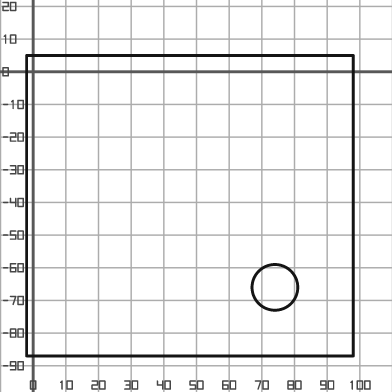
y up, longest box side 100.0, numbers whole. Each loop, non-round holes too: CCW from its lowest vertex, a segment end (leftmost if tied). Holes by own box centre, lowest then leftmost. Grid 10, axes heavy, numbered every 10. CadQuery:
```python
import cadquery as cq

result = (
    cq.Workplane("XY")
    .moveTo(-2.0, -87.0)
    .lineTo(98.0, -87.0)
    .lineTo(98.0, 5.0)
    .lineTo(-2.0, 5.0)
    .close()
    .moveTo(74.0, -66.0)
    .circle(7.0)
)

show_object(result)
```